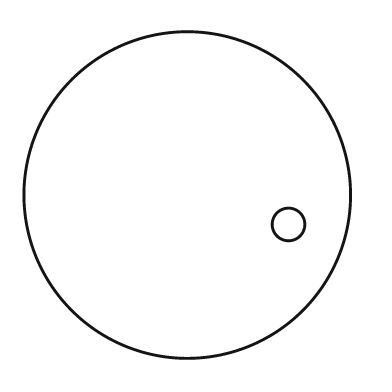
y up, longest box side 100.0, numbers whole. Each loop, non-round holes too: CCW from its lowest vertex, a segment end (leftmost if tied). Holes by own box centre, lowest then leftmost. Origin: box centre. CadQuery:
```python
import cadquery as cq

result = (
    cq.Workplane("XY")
    .moveTo(0.0, 0.0)
    .circle(50.0)
    .moveTo(31.0, -9.0)
    .circle(5.0)
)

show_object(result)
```